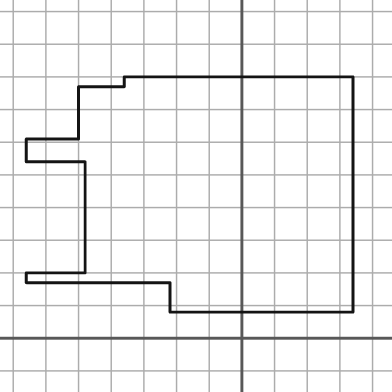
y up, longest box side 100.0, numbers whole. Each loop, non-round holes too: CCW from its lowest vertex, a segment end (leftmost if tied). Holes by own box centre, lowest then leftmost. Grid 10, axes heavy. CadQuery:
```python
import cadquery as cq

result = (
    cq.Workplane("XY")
    .moveTo(-22.0, 8.0)
    .lineTo(34.0, 8.0)
    .lineTo(34.0, 80.0)
    .lineTo(-36.0, 80.0)
    .lineTo(-36.0, 77.0)
    .lineTo(-50.0, 77.0)
    .lineTo(-50.0, 61.0)
    .lineTo(-66.0, 61.0)
    .lineTo(-66.0, 54.0)
    .lineTo(-48.0, 54.0)
    .lineTo(-48.0, 20.0)
    .lineTo(-66.0, 20.0)
    .lineTo(-66.0, 17.0)
    .lineTo(-22.0, 17.0)
    .close()
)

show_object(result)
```